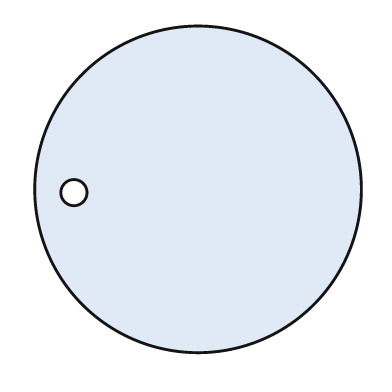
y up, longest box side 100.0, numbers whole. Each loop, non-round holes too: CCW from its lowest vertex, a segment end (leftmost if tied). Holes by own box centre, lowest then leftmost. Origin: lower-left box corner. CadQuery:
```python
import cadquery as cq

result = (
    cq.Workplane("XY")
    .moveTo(50.0, 50.0)
    .circle(50.0)
    .moveTo(12.0, 49.0)
    .circle(4.0)
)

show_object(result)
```